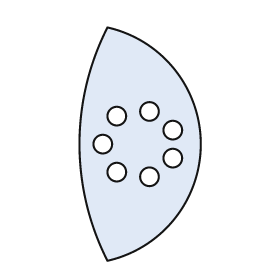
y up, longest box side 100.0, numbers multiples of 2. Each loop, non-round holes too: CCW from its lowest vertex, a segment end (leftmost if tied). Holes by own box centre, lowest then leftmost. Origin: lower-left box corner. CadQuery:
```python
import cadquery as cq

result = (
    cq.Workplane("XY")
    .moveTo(12.0, 0.0)
    .threePointArc((52.0, 50.0), (12.0, 100.0))
    .threePointArc((0.0, 50.0), (12.0, 0.0))
    .close()
    .moveTo(30.0, 36.0)
    .circle(4.0)
    .moveTo(16.0, 38.0)
    .circle(4.0)
    .moveTo(40.0, 44.0)
    .circle(4.0)
    .moveTo(10.0, 50.0)
    .circle(4.0)
    .moveTo(40.0, 56.0)
    .circle(4.0)
    .moveTo(16.0, 62.0)
    .circle(4.0)
    .moveTo(30.0, 64.0)
    .circle(4.0)
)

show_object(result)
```